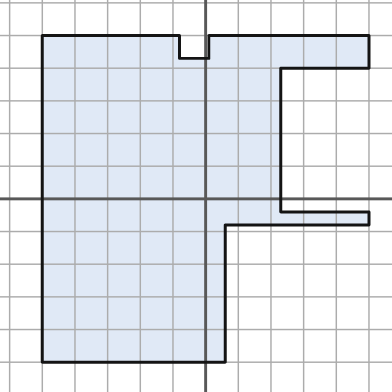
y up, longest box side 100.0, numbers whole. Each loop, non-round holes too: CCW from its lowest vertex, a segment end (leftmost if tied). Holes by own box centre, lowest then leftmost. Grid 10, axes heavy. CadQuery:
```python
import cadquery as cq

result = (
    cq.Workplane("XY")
    .moveTo(-50.0, -50.0)
    .lineTo(6.0, -50.0)
    .lineTo(6.0, -8.0)
    .lineTo(50.0, -8.0)
    .lineTo(50.0, -4.0)
    .lineTo(23.0, -4.0)
    .lineTo(23.0, 40.0)
    .lineTo(50.0, 40.0)
    .lineTo(50.0, 50.0)
    .lineTo(1.0, 50.0)
    .lineTo(1.0, 43.0)
    .lineTo(-8.0, 43.0)
    .lineTo(-8.0, 50.0)
    .lineTo(-50.0, 50.0)
    .close()
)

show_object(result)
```